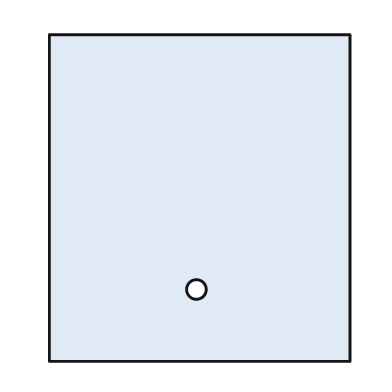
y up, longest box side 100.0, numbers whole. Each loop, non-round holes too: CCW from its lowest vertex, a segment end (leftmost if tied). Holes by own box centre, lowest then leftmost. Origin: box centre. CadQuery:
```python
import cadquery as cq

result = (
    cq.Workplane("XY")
    .moveTo(-46.0, -50.0)
    .lineTo(46.0, -50.0)
    .lineTo(46.0, 50.0)
    .lineTo(-46.0, 50.0)
    .close()
    .moveTo(-1.0, -28.0)
    .circle(3.0)
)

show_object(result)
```